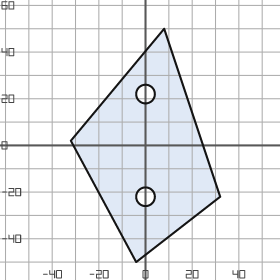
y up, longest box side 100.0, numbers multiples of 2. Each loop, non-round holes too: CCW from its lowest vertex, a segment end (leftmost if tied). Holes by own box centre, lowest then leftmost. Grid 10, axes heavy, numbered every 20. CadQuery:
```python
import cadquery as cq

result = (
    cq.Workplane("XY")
    .moveTo(-4.0, -50.0)
    .lineTo(32.0, -22.0)
    .lineTo(8.0, 50.0)
    .lineTo(-32.0, 2.0)
    .close()
    .moveTo(0.0, -22.0)
    .circle(4.0)
    .moveTo(0.0, 22.0)
    .circle(4.0)
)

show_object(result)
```